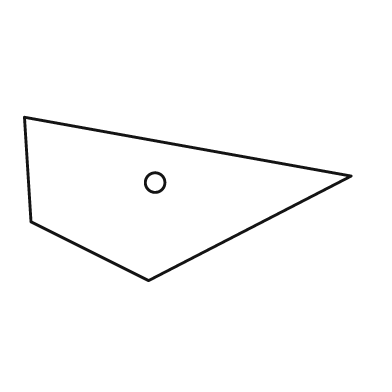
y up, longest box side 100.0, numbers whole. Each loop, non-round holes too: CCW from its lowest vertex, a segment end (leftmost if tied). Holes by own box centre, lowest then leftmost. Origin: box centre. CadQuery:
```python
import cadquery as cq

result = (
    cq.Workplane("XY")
    .moveTo(-12.0, -25.0)
    .lineTo(50.0, 7.0)
    .lineTo(-50.0, 25.0)
    .lineTo(-48.0, -7.0)
    .close()
    .moveTo(-10.0, 5.0)
    .circle(3.0)
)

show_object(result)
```